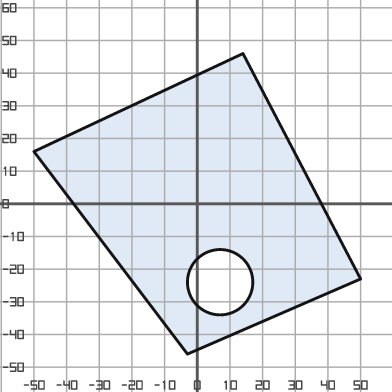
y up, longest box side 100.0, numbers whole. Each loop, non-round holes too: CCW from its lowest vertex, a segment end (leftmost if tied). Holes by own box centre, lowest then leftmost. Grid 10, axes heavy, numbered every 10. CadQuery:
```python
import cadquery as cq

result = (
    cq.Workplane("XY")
    .moveTo(-3.0, -46.0)
    .lineTo(50.0, -23.0)
    .lineTo(14.0, 46.0)
    .lineTo(-50.0, 16.0)
    .close()
    .moveTo(7.0, -24.0)
    .circle(10.0)
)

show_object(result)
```